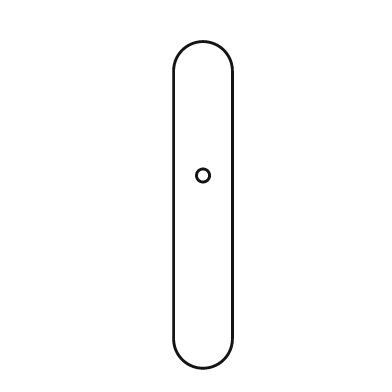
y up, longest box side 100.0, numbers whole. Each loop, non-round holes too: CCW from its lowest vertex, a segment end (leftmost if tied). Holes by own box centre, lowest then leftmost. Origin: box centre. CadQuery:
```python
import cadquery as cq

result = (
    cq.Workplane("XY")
    .moveTo(-9.0, -41.0)
    .threePointArc((0.0, -50.0), (9.0, -41.0))
    .lineTo(9.0, 41.0)
    .threePointArc((0.0, 50.0), (-9.0, 41.0))
    .close()
    .moveTo(0.0, 9.0)
    .circle(2.0)
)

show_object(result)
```